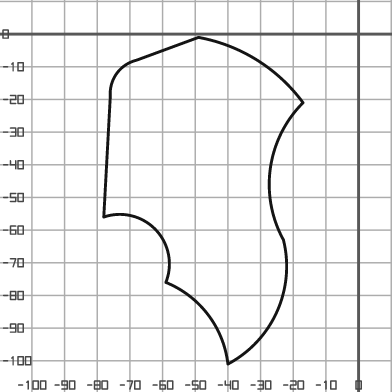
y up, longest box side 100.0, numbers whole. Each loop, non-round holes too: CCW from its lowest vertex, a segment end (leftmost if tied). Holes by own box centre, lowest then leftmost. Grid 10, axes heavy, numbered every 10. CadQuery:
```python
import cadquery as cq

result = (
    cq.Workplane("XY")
    .moveTo(-40.0, -101.0)
    .threePointArc((-25.0, -85.0), (-23.0, -63.0))
    .threePointArc((-27.0, -41.0), (-17.0, -21.0))
    .threePointArc((-31.0, -8.0), (-49.0, -1.0))
    .lineTo(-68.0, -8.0)
    .threePointArc((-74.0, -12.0), (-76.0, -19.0))
    .lineTo(-78.0, -56.0)
    .threePointArc((-62.0, -60.0), (-59.0, -76.0))
    .threePointArc((-46.0, -86.0), (-40.0, -101.0))
    .close()
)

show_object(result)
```